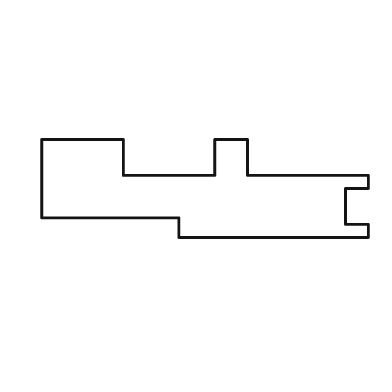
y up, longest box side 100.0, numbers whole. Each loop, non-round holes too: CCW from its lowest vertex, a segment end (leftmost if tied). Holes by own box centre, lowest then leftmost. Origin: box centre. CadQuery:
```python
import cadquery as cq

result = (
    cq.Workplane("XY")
    .moveTo(-8.0, -15.0)
    .lineTo(50.0, -15.0)
    .lineTo(50.0, -11.0)
    .lineTo(43.0, -11.0)
    .lineTo(43.0, 0.0)
    .lineTo(50.0, 0.0)
    .lineTo(50.0, 4.0)
    .lineTo(13.0, 4.0)
    .lineTo(13.0, 15.0)
    .lineTo(3.0, 15.0)
    .lineTo(3.0, 4.0)
    .lineTo(-25.0, 4.0)
    .lineTo(-25.0, 15.0)
    .lineTo(-50.0, 15.0)
    .lineTo(-50.0, -9.0)
    .lineTo(-8.0, -9.0)
    .close()
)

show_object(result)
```